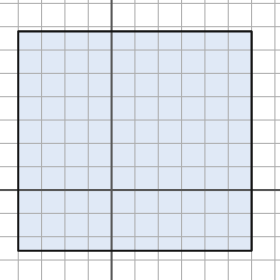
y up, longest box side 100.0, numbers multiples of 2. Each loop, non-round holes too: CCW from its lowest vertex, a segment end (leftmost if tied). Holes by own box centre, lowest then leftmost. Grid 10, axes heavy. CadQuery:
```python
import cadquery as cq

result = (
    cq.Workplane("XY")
    .moveTo(-40.0, -26.0)
    .lineTo(60.0, -26.0)
    .lineTo(60.0, 68.0)
    .lineTo(-40.0, 68.0)
    .close()
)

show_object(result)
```